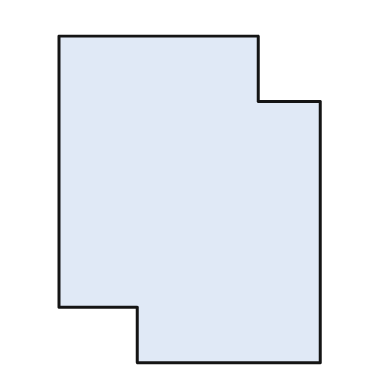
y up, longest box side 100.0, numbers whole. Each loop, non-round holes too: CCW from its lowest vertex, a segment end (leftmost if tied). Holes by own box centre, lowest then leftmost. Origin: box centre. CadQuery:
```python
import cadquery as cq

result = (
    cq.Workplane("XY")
    .moveTo(-16.0, -50.0)
    .lineTo(40.0, -50.0)
    .lineTo(40.0, 30.0)
    .lineTo(21.0, 30.0)
    .lineTo(21.0, 50.0)
    .lineTo(-40.0, 50.0)
    .lineTo(-40.0, -33.0)
    .lineTo(-16.0, -33.0)
    .close()
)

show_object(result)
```